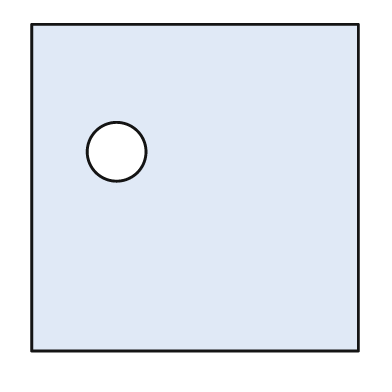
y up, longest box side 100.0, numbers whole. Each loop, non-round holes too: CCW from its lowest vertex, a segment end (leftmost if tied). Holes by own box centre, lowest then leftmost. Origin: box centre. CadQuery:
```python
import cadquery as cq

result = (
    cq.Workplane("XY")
    .moveTo(-50.0, -50.0)
    .lineTo(50.0, -50.0)
    .lineTo(50.0, 50.0)
    .lineTo(-50.0, 50.0)
    .close()
    .moveTo(-24.0, 11.0)
    .circle(9.0)
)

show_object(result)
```